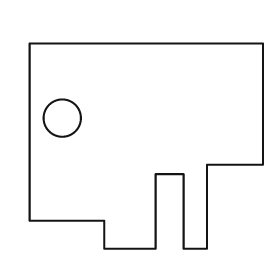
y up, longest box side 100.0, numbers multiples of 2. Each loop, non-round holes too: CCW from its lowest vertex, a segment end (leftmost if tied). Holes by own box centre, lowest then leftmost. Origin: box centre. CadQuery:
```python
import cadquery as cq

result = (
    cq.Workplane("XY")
    .moveTo(-18.0, -44.0)
    .lineTo(4.0, -44.0)
    .lineTo(4.0, -12.0)
    .lineTo(16.0, -12.0)
    .lineTo(16.0, -44.0)
    .lineTo(26.0, -44.0)
    .lineTo(26.0, -8.0)
    .lineTo(50.0, -8.0)
    .lineTo(50.0, 44.0)
    .lineTo(-50.0, 44.0)
    .lineTo(-50.0, -32.0)
    .lineTo(-18.0, -32.0)
    .close()
    .moveTo(-36.0, 12.0)
    .circle(8.0)
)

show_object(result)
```